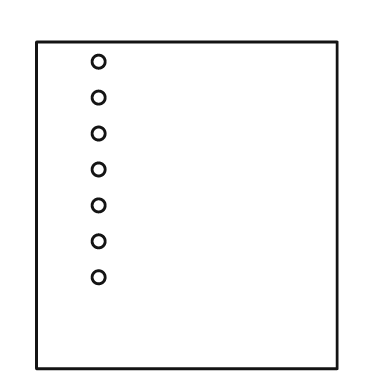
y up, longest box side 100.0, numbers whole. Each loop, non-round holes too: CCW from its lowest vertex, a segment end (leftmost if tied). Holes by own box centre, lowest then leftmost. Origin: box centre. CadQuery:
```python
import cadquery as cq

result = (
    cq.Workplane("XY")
    .moveTo(-46.0, -50.0)
    .lineTo(46.0, -50.0)
    .lineTo(46.0, 50.0)
    .lineTo(-46.0, 50.0)
    .close()
    .moveTo(-27.0, -22.0)
    .circle(2.0)
    .moveTo(-27.0, -11.0)
    .circle(2.0)
    .moveTo(-27.0, 0.0)
    .circle(2.0)
    .moveTo(-27.0, 11.0)
    .circle(2.0)
    .moveTo(-27.0, 22.0)
    .circle(2.0)
    .moveTo(-27.0, 33.0)
    .circle(2.0)
    .moveTo(-27.0, 44.0)
    .circle(2.0)
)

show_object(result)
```